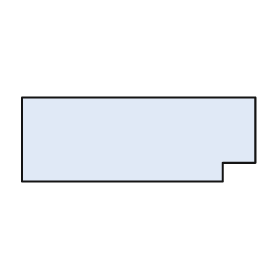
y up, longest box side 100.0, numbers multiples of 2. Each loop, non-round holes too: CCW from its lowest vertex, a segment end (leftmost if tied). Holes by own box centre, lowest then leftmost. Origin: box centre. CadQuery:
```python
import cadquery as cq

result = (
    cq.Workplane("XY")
    .moveTo(-50.0, -18.0)
    .lineTo(36.0, -18.0)
    .lineTo(36.0, -10.0)
    .lineTo(50.0, -10.0)
    .lineTo(50.0, 18.0)
    .lineTo(-50.0, 18.0)
    .close()
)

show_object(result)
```